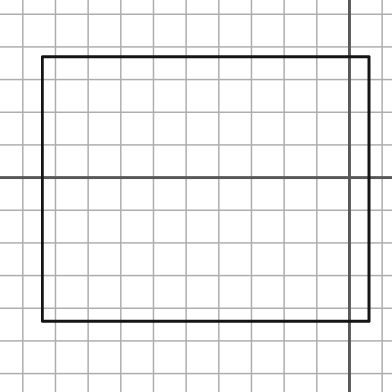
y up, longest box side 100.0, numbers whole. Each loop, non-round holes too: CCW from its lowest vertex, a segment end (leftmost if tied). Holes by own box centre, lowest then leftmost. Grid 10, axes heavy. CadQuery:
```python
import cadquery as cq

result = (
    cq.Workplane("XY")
    .moveTo(-94.0, -44.0)
    .lineTo(6.0, -44.0)
    .lineTo(6.0, 37.0)
    .lineTo(-94.0, 37.0)
    .close()
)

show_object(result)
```